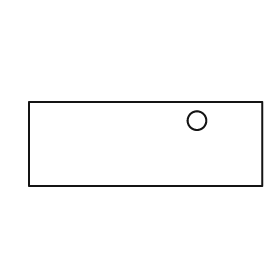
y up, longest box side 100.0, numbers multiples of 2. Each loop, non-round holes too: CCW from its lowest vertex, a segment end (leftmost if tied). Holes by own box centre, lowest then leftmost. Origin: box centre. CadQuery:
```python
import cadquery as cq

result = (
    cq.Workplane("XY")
    .moveTo(-50.0, -18.0)
    .lineTo(50.0, -18.0)
    .lineTo(50.0, 18.0)
    .lineTo(-50.0, 18.0)
    .close()
    .moveTo(22.0, 10.0)
    .circle(4.0)
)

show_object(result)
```